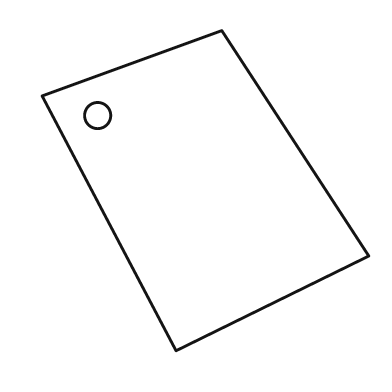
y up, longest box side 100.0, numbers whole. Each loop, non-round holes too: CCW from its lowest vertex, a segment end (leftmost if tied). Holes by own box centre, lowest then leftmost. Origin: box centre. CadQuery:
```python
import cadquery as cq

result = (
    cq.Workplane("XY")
    .moveTo(-9.0, -49.0)
    .lineTo(50.0, -20.0)
    .lineTo(5.0, 49.0)
    .lineTo(-50.0, 29.0)
    .close()
    .moveTo(-33.0, 23.0)
    .circle(4.0)
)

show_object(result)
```